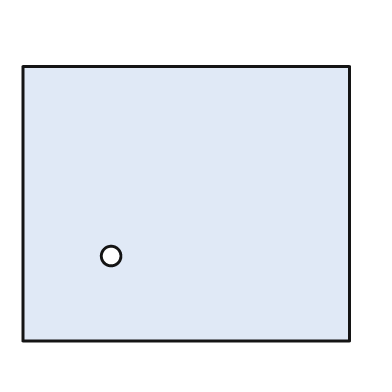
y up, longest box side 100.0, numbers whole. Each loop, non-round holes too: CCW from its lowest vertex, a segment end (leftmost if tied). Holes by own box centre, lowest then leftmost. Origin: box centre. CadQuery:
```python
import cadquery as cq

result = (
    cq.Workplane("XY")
    .moveTo(-50.0, -42.0)
    .lineTo(50.0, -42.0)
    .lineTo(50.0, 42.0)
    .lineTo(-50.0, 42.0)
    .close()
    .moveTo(-23.0, -16.0)
    .circle(3.0)
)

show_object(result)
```